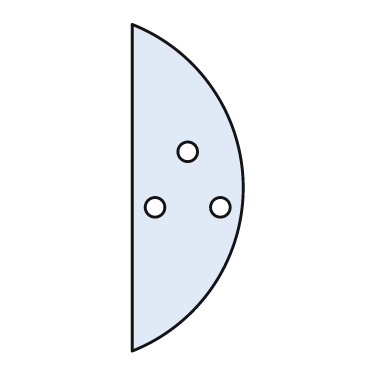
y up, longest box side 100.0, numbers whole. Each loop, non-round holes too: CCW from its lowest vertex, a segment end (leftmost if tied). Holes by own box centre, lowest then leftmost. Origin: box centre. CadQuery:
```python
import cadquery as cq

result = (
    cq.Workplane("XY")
    .moveTo(-17.0, -50.0)
    .threePointArc((17.0, 0.0), (-17.0, 50.0))
    .close()
    .moveTo(-10.0, -6.0)
    .circle(3.0)
    .moveTo(10.0, -6.0)
    .circle(3.0)
    .moveTo(0.0, 11.0)
    .circle(3.0)
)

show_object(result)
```